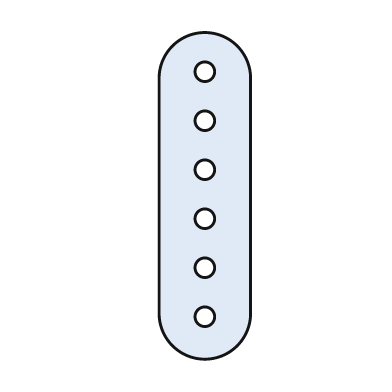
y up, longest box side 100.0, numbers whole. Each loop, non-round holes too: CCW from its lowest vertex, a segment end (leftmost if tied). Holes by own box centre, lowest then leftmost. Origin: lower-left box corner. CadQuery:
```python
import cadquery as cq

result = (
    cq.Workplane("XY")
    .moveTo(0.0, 14.0)
    .threePointArc((14.0, 0.0), (28.0, 14.0))
    .lineTo(28.0, 86.0)
    .threePointArc((14.0, 100.0), (0.0, 86.0))
    .close()
    .moveTo(14.0, 13.0)
    .circle(3.0)
    .moveTo(14.0, 28.0)
    .circle(3.0)
    .moveTo(14.0, 43.0)
    .circle(3.0)
    .moveTo(14.0, 58.0)
    .circle(3.0)
    .moveTo(14.0, 73.0)
    .circle(3.0)
    .moveTo(14.0, 88.0)
    .circle(3.0)
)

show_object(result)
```